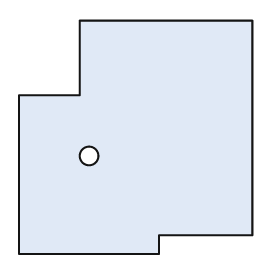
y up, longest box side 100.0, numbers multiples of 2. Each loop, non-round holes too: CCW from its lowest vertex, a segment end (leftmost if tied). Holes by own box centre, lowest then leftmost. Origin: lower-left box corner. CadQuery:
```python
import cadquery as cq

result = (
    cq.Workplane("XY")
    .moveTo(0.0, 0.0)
    .lineTo(60.0, 0.0)
    .lineTo(60.0, 8.0)
    .lineTo(100.0, 8.0)
    .lineTo(100.0, 100.0)
    .lineTo(26.0, 100.0)
    .lineTo(26.0, 68.0)
    .lineTo(0.0, 68.0)
    .close()
    .moveTo(30.0, 42.0)
    .circle(4.0)
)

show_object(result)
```